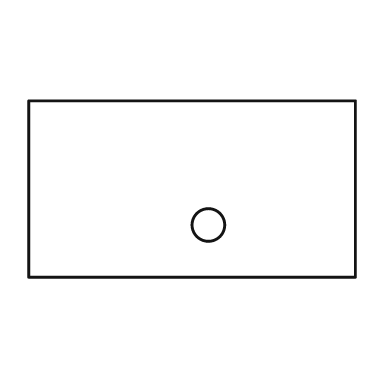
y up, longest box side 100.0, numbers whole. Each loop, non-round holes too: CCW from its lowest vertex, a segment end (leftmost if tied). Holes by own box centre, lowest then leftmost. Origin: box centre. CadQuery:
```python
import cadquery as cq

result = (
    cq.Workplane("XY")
    .moveTo(-50.0, -27.0)
    .lineTo(50.0, -27.0)
    .lineTo(50.0, 27.0)
    .lineTo(-50.0, 27.0)
    .close()
    .moveTo(5.0, -11.0)
    .circle(5.0)
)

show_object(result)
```